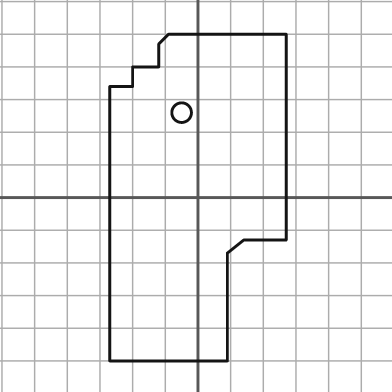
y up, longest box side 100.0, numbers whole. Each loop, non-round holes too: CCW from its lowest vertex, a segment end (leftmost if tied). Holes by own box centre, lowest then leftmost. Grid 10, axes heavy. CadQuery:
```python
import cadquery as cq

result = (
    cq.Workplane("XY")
    .moveTo(-27.0, -50.0)
    .lineTo(9.0, -50.0)
    .lineTo(9.0, -17.0)
    .lineTo(14.0, -13.0)
    .lineTo(27.0, -13.0)
    .lineTo(27.0, 50.0)
    .lineTo(-9.0, 50.0)
    .lineTo(-12.0, 47.0)
    .lineTo(-12.0, 40.0)
    .lineTo(-20.0, 40.0)
    .lineTo(-20.0, 34.0)
    .lineTo(-27.0, 34.0)
    .close()
    .moveTo(-5.0, 26.0)
    .circle(3.0)
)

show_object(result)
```